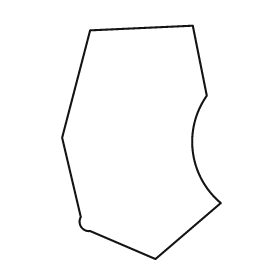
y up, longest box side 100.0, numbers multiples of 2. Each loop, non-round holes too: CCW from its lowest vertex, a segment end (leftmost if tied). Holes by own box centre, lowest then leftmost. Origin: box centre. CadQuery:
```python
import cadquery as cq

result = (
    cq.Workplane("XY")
    .moveTo(6.0, -50.0)
    .lineTo(34.0, -26.0)
    .threePointArc((22.0, -4.0), (28.0, 20.0))
    .lineTo(22.0, 50.0)
    .lineTo(-22.0, 48.0)
    .lineTo(-34.0, 2.0)
    .lineTo(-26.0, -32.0)
    .threePointArc((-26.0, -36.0), (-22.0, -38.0))
    .close()
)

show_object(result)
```